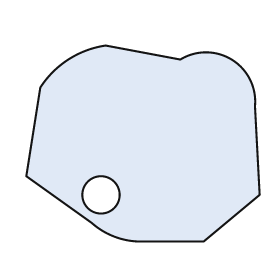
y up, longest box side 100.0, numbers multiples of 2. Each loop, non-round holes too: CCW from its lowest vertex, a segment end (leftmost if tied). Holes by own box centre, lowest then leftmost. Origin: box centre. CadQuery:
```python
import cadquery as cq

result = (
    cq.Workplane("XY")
    .moveTo(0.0, -42.0)
    .lineTo(26.0, -42.0)
    .lineTo(50.0, -22.0)
    .lineTo(48.0, 16.0)
    .threePointArc((38.0, 36.0), (16.0, 36.0))
    .lineTo(-16.0, 42.0)
    .threePointArc((-32.0, 36.0), (-44.0, 24.0))
    .lineTo(-50.0, -14.0)
    .lineTo(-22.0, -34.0)
    .threePointArc((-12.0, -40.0), (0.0, -42.0))
    .close()
    .moveTo(-18.0, -22.0)
    .circle(8.0)
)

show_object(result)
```